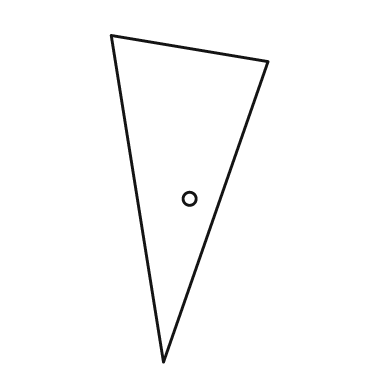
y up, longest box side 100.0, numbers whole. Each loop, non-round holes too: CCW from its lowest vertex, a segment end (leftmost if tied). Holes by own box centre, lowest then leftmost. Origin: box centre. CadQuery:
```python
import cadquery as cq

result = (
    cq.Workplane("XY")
    .moveTo(-8.0, -50.0)
    .lineTo(24.0, 42.0)
    .lineTo(-24.0, 50.0)
    .close()
    .moveTo(0.0, 0.0)
    .circle(2.0)
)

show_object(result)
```